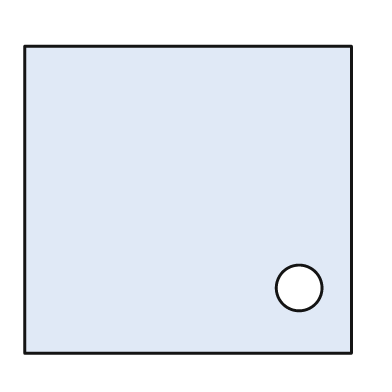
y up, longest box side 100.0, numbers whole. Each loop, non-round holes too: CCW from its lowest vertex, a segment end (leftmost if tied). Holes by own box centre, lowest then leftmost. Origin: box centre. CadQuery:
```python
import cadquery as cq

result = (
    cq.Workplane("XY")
    .moveTo(-50.0, -47.0)
    .lineTo(50.0, -47.0)
    .lineTo(50.0, 47.0)
    .lineTo(-50.0, 47.0)
    .close()
    .moveTo(34.0, -27.0)
    .circle(7.0)
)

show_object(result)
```